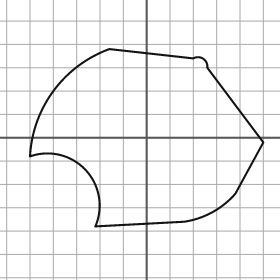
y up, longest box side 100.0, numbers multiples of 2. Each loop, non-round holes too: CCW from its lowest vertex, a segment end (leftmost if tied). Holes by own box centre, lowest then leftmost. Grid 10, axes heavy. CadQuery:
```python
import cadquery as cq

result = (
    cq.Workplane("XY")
    .moveTo(-22.0, -38.0)
    .lineTo(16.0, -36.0)
    .threePointArc((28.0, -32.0), (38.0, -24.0))
    .lineTo(50.0, -2.0)
    .lineTo(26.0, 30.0)
    .threePointArc((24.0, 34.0), (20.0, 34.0))
    .lineTo(-16.0, 38.0)
    .threePointArc((-40.0, 20.0), (-50.0, -8.0))
    .threePointArc((-26.0, -14.0), (-22.0, -38.0))
    .close()
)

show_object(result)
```